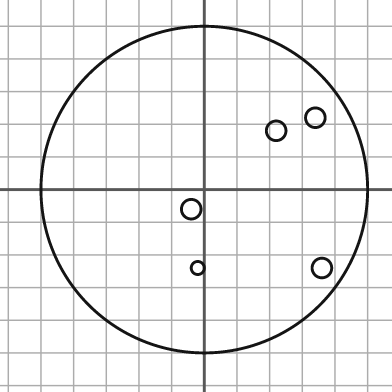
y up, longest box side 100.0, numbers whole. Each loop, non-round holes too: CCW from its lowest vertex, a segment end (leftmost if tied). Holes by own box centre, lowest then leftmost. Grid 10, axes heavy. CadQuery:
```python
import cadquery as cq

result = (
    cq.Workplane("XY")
    .moveTo(0.0, 0.0)
    .circle(50.0)
    .moveTo(-2.0, -24.0)
    .circle(2.0)
    .moveTo(36.0, -24.0)
    .circle(3.0)
    .moveTo(-4.0, -6.0)
    .circle(3.0)
    .moveTo(22.0, 18.0)
    .circle(3.0)
    .moveTo(34.0, 22.0)
    .circle(3.0)
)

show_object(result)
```